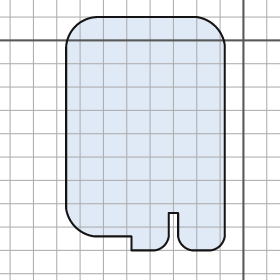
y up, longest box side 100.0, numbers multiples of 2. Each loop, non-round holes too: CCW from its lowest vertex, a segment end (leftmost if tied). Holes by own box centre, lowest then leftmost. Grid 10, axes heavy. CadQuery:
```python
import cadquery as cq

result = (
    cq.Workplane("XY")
    .moveTo(-48.0, -90.0)
    .lineTo(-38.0, -90.0)
    .threePointArc((-34.0, -88.0), (-32.0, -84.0))
    .lineTo(-32.0, -74.0)
    .lineTo(-28.0, -74.0)
    .lineTo(-28.0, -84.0)
    .threePointArc((-26.0, -88.0), (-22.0, -90.0))
    .lineTo(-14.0, -90.0)
    .threePointArc((-10.0, -88.0), (-8.0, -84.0))
    .lineTo(-8.0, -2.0)
    .threePointArc((-12.0, 6.0), (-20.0, 10.0))
    .lineTo(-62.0, 10.0)
    .threePointArc((-72.0, 6.0), (-76.0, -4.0))
    .lineTo(-76.0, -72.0)
    .threePointArc((-72.0, -80.0), (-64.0, -84.0))
    .lineTo(-48.0, -84.0)
    .close()
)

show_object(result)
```